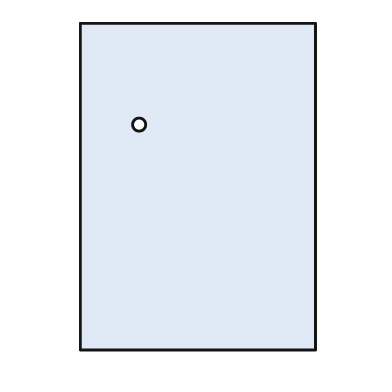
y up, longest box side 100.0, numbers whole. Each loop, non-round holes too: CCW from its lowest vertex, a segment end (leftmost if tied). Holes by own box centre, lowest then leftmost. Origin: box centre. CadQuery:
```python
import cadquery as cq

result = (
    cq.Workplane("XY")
    .moveTo(-36.0, -50.0)
    .lineTo(36.0, -50.0)
    .lineTo(36.0, 50.0)
    .lineTo(-36.0, 50.0)
    .close()
    .moveTo(-18.0, 19.0)
    .circle(2.0)
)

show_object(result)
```